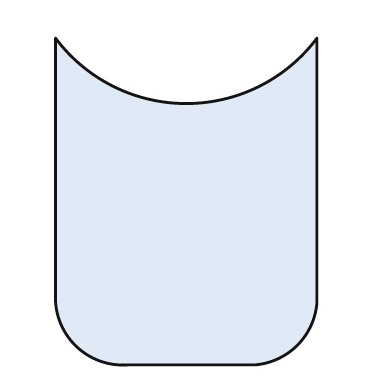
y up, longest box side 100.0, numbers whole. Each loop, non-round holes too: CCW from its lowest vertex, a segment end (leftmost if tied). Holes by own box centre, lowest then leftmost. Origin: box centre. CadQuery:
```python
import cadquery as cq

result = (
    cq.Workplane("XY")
    .moveTo(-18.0, -50.0)
    .lineTo(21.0, -50.0)
    .threePointArc((34.0, -44.0), (40.0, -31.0))
    .lineTo(40.0, 50.0)
    .threePointArc((0.0, 30.0), (-40.0, 50.0))
    .lineTo(-40.0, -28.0)
    .threePointArc((-34.0, -44.0), (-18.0, -50.0))
    .close()
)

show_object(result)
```